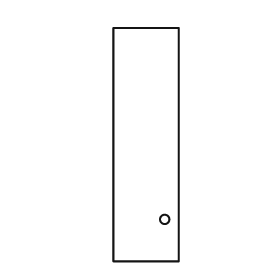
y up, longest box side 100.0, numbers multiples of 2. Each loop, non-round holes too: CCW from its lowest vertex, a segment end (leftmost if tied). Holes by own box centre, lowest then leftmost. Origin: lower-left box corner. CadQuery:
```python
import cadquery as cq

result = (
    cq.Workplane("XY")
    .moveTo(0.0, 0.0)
    .lineTo(28.0, 0.0)
    .lineTo(28.0, 100.0)
    .lineTo(0.0, 100.0)
    .close()
    .moveTo(22.0, 18.0)
    .circle(2.0)
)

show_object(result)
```